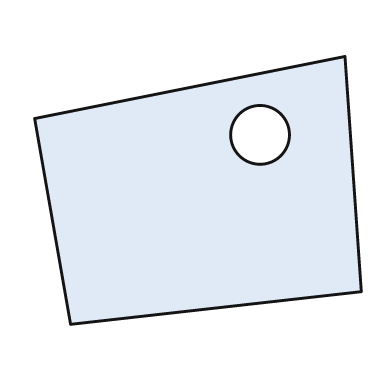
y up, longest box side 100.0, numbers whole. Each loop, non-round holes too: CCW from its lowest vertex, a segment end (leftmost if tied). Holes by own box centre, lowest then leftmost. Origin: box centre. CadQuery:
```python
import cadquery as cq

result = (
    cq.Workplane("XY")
    .moveTo(-39.0, -41.0)
    .lineTo(50.0, -31.0)
    .lineTo(45.0, 41.0)
    .lineTo(-50.0, 22.0)
    .close()
    .moveTo(19.0, 17.0)
    .circle(9.0)
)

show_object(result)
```